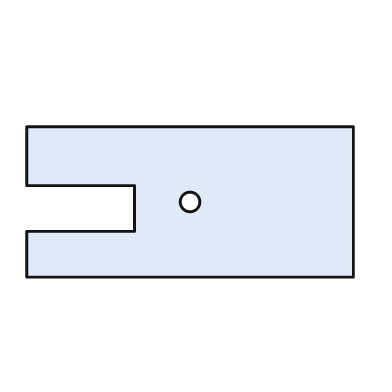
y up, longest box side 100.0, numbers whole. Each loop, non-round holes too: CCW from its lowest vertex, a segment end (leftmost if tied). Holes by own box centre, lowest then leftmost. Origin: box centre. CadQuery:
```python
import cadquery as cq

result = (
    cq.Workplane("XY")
    .moveTo(-50.0, -23.0)
    .lineTo(50.0, -23.0)
    .lineTo(50.0, 23.0)
    .lineTo(-50.0, 23.0)
    .lineTo(-50.0, 5.0)
    .lineTo(-17.0, 5.0)
    .lineTo(-17.0, -9.0)
    .lineTo(-50.0, -9.0)
    .close()
    .moveTo(0.0, 0.0)
    .circle(3.0)
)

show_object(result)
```